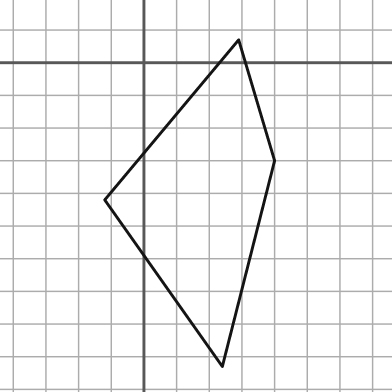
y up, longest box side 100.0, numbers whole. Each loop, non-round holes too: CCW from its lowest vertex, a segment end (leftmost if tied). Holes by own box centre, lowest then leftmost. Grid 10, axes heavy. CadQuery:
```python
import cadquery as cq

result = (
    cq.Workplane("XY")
    .moveTo(24.0, -93.0)
    .lineTo(40.0, -30.0)
    .lineTo(29.0, 7.0)
    .lineTo(-12.0, -42.0)
    .close()
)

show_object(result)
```